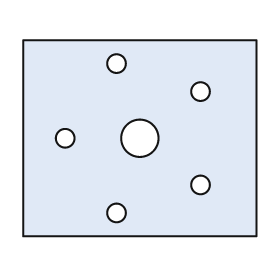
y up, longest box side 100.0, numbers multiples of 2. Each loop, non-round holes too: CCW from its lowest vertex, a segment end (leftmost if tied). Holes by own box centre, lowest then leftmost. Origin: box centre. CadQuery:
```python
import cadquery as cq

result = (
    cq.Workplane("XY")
    .moveTo(-50.0, -42.0)
    .lineTo(50.0, -42.0)
    .lineTo(50.0, 42.0)
    .lineTo(-50.0, 42.0)
    .close()
    .moveTo(-10.0, -32.0)
    .circle(4.0)
    .moveTo(26.0, -20.0)
    .circle(4.0)
    .moveTo(-32.0, 0.0)
    .circle(4.0)
    .moveTo(0.0, 0.0)
    .circle(8.0)
    .moveTo(26.0, 20.0)
    .circle(4.0)
    .moveTo(-10.0, 32.0)
    .circle(4.0)
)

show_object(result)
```